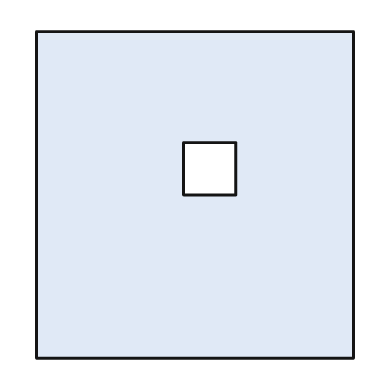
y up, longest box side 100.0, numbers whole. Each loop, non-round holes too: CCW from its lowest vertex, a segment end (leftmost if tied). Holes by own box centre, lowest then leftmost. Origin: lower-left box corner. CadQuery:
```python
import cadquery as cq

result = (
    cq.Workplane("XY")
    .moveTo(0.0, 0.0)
    .lineTo(97.0, 0.0)
    .lineTo(97.0, 100.0)
    .lineTo(0.0, 100.0)
    .close()
    .moveTo(45.0, 50.0)
    .lineTo(61.0, 50.0)
    .lineTo(61.0, 66.0)
    .lineTo(45.0, 66.0)
    .close()
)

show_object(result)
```